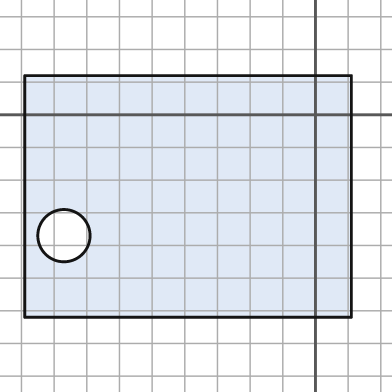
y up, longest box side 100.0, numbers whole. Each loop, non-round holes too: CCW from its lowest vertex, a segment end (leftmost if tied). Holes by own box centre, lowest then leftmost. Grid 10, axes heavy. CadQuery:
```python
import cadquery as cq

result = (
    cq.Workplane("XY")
    .moveTo(-89.0, -62.0)
    .lineTo(11.0, -62.0)
    .lineTo(11.0, 12.0)
    .lineTo(-89.0, 12.0)
    .close()
    .moveTo(-77.0, -37.0)
    .circle(8.0)
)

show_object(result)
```